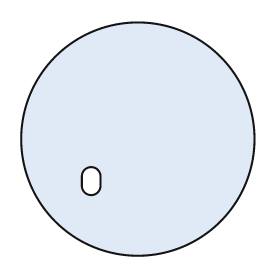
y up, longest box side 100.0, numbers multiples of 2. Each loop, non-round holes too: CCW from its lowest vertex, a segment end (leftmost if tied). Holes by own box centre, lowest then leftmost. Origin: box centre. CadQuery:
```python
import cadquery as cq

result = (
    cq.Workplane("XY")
    .moveTo(0.0, 0.0)
    .circle(50.0)
    .moveTo(-24.0, -20.0)
    .threePointArc((-20.0, -24.0), (-16.0, -20.0))
    .lineTo(-16.0, -16.0)
    .threePointArc((-20.0, -12.0), (-24.0, -16.0))
    .close()
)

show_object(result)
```